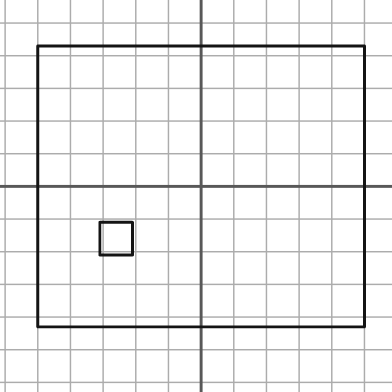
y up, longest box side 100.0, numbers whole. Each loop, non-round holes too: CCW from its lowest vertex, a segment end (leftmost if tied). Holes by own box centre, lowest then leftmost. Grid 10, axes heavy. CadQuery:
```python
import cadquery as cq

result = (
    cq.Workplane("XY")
    .moveTo(-50.0, -43.0)
    .lineTo(50.0, -43.0)
    .lineTo(50.0, 43.0)
    .lineTo(-50.0, 43.0)
    .close()
    .moveTo(-31.0, -21.0)
    .lineTo(-21.0, -21.0)
    .lineTo(-21.0, -11.0)
    .lineTo(-31.0, -11.0)
    .close()
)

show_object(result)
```